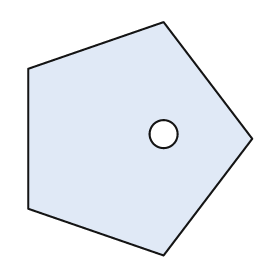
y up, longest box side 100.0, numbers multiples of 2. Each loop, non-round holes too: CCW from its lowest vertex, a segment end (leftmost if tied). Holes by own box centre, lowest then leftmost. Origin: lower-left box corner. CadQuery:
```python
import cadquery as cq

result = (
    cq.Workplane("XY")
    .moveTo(58.0, 0.0)
    .lineTo(96.0, 50.0)
    .lineTo(58.0, 100.0)
    .lineTo(0.0, 80.0)
    .lineTo(0.0, 20.0)
    .close()
    .moveTo(58.0, 52.0)
    .circle(6.0)
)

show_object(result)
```